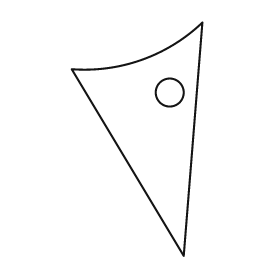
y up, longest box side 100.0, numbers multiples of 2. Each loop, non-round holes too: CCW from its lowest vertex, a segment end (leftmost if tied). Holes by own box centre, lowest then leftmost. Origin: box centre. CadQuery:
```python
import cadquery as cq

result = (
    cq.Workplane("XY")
    .moveTo(20.0, -50.0)
    .lineTo(28.0, 50.0)
    .threePointArc((2.0, 34.0), (-28.0, 30.0))
    .close()
    .moveTo(14.0, 20.0)
    .circle(6.0)
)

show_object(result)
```